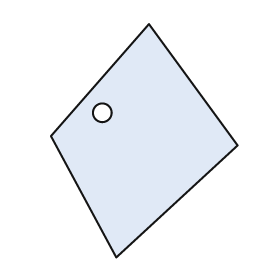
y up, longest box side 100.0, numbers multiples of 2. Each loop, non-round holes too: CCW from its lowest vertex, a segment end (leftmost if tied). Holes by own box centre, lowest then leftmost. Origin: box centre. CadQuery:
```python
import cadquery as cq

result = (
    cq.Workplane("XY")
    .moveTo(-12.0, -50.0)
    .lineTo(40.0, -2.0)
    .lineTo(2.0, 50.0)
    .lineTo(-40.0, 2.0)
    .close()
    .moveTo(-18.0, 12.0)
    .circle(4.0)
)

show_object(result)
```